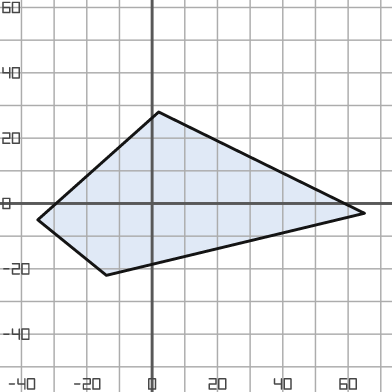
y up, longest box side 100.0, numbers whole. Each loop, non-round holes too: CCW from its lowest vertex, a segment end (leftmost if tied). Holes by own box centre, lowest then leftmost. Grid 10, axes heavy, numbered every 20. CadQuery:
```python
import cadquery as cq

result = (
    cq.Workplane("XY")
    .moveTo(-14.0, -22.0)
    .lineTo(65.0, -3.0)
    .lineTo(2.0, 28.0)
    .lineTo(-35.0, -5.0)
    .close()
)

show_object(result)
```